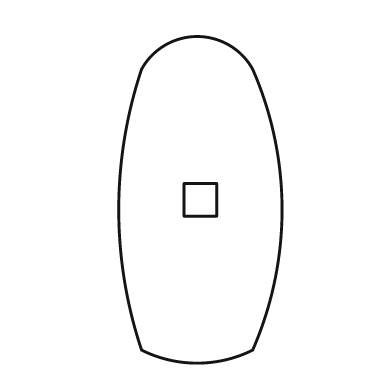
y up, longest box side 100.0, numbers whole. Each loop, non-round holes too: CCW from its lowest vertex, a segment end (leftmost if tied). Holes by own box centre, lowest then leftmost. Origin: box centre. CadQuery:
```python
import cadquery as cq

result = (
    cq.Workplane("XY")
    .moveTo(-18.0, -46.0)
    .threePointArc((-1.0, -50.0), (16.0, -46.0))
    .threePointArc((25.0, -3.0), (16.0, 40.0))
    .threePointArc((-1.0, 50.0), (-18.0, 40.0))
    .threePointArc((-25.0, -3.0), (-18.0, -46.0))
    .close()
    .moveTo(-5.0, -5.0)
    .lineTo(5.0, -5.0)
    .lineTo(5.0, 5.0)
    .lineTo(-5.0, 5.0)
    .close()
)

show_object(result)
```